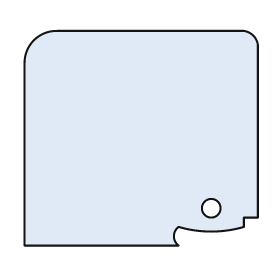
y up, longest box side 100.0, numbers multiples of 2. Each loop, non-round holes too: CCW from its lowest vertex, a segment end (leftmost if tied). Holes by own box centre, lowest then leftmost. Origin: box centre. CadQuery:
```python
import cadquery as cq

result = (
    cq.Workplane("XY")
    .moveTo(-50.0, -46.0)
    .lineTo(16.0, -46.0)
    .threePointArc((14.0, -42.0), (16.0, -38.0))
    .threePointArc((30.0, -40.0), (44.0, -38.0))
    .lineTo(44.0, -34.0)
    .lineTo(50.0, -34.0)
    .lineTo(50.0, 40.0)
    .threePointArc((48.0, 44.0), (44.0, 46.0))
    .lineTo(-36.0, 46.0)
    .threePointArc((-46.0, 42.0), (-50.0, 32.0))
    .close()
    .moveTo(30.0, -30.0)
    .circle(4.0)
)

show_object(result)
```